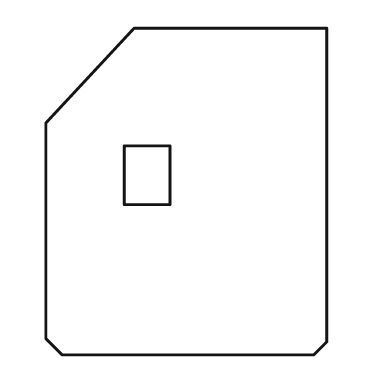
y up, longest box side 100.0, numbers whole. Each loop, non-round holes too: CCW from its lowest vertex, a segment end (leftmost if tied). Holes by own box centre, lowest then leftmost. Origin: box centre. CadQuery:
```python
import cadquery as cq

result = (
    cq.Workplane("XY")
    .moveTo(-38.0, -50.0)
    .lineTo(39.0, -50.0)
    .lineTo(43.0, -46.0)
    .lineTo(43.0, 50.0)
    .lineTo(-16.0, 50.0)
    .lineTo(-43.0, 21.0)
    .lineTo(-43.0, -45.0)
    .close()
    .moveTo(-19.0, -4.0)
    .lineTo(-5.0, -4.0)
    .lineTo(-5.0, 14.0)
    .lineTo(-19.0, 14.0)
    .close()
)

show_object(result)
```